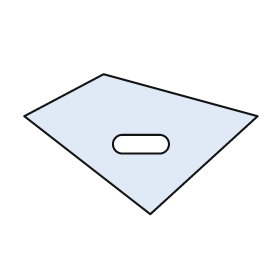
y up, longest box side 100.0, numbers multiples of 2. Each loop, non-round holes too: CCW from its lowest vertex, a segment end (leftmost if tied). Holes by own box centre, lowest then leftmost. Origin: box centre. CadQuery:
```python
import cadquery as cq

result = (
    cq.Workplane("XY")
    .moveTo(4.0, -30.0)
    .lineTo(50.0, 12.0)
    .lineTo(-16.0, 30.0)
    .lineTo(-50.0, 12.0)
    .close()
    .moveTo(-8.0, -4.0)
    .lineTo(8.0, -4.0)
    .threePointArc((12.0, 0.0), (8.0, 4.0))
    .lineTo(-8.0, 4.0)
    .threePointArc((-12.0, 0.0), (-8.0, -4.0))
    .close()
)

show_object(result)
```